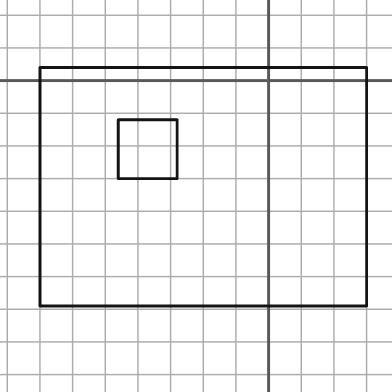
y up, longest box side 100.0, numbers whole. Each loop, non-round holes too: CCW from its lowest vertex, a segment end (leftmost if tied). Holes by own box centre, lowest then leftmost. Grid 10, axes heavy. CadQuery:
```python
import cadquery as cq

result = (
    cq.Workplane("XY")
    .moveTo(-70.0, -69.0)
    .lineTo(30.0, -69.0)
    .lineTo(30.0, 4.0)
    .lineTo(-70.0, 4.0)
    .close()
    .moveTo(-46.0, -30.0)
    .lineTo(-28.0, -30.0)
    .lineTo(-28.0, -12.0)
    .lineTo(-46.0, -12.0)
    .close()
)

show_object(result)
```